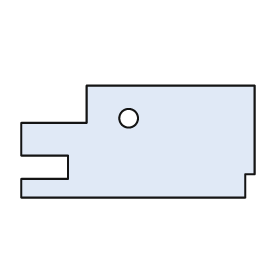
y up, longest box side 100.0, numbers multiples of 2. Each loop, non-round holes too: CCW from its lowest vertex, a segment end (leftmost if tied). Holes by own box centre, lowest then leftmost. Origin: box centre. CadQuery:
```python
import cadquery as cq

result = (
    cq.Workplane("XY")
    .moveTo(-50.0, -24.0)
    .lineTo(46.0, -24.0)
    .lineTo(46.0, -14.0)
    .lineTo(50.0, -14.0)
    .lineTo(50.0, 24.0)
    .lineTo(-22.0, 24.0)
    .lineTo(-22.0, 8.0)
    .lineTo(-50.0, 8.0)
    .lineTo(-50.0, -6.0)
    .lineTo(-30.0, -6.0)
    .lineTo(-30.0, -16.0)
    .lineTo(-50.0, -16.0)
    .close()
    .moveTo(-4.0, 10.0)
    .circle(4.0)
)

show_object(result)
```